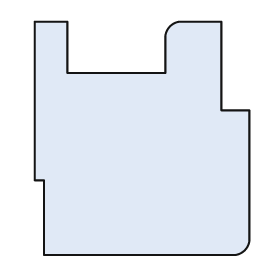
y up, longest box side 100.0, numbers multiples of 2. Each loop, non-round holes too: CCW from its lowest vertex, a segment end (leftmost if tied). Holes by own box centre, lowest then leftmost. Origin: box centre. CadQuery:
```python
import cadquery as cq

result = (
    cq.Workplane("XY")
    .moveTo(-42.0, -50.0)
    .lineTo(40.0, -50.0)
    .threePointArc((44.0, -48.0), (46.0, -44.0))
    .lineTo(46.0, 12.0)
    .lineTo(34.0, 12.0)
    .lineTo(34.0, 50.0)
    .lineTo(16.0, 50.0)
    .threePointArc((12.0, 48.0), (10.0, 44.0))
    .lineTo(10.0, 28.0)
    .lineTo(-32.0, 28.0)
    .lineTo(-32.0, 50.0)
    .lineTo(-46.0, 50.0)
    .lineTo(-46.0, -18.0)
    .lineTo(-42.0, -18.0)
    .close()
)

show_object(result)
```